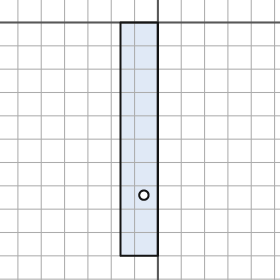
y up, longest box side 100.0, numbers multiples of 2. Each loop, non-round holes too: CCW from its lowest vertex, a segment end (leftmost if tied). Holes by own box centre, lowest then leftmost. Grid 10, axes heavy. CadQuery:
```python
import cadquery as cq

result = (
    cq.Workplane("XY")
    .moveTo(-16.0, -100.0)
    .lineTo(0.0, -100.0)
    .lineTo(0.0, 0.0)
    .lineTo(-16.0, 0.0)
    .close()
    .moveTo(-6.0, -74.0)
    .circle(2.0)
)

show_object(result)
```